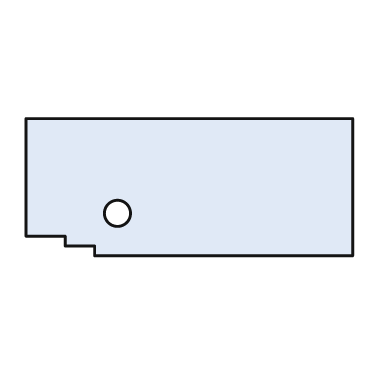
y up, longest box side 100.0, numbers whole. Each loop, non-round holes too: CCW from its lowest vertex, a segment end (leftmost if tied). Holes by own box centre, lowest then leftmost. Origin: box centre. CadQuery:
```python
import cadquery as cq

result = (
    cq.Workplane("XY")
    .moveTo(-29.0, -21.0)
    .lineTo(50.0, -21.0)
    .lineTo(50.0, 21.0)
    .lineTo(-50.0, 21.0)
    .lineTo(-50.0, -15.0)
    .lineTo(-38.0, -15.0)
    .lineTo(-38.0, -18.0)
    .lineTo(-29.0, -18.0)
    .close()
    .moveTo(-22.0, -8.0)
    .circle(4.0)
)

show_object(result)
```